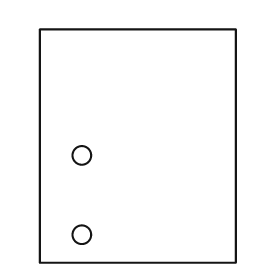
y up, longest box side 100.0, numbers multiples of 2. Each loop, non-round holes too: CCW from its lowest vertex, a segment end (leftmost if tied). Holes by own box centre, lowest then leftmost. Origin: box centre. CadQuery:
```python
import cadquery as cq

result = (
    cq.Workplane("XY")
    .moveTo(-42.0, -50.0)
    .lineTo(42.0, -50.0)
    .lineTo(42.0, 50.0)
    .lineTo(-42.0, 50.0)
    .close()
    .moveTo(-24.0, -38.0)
    .circle(4.0)
    .moveTo(-24.0, -4.0)
    .circle(4.0)
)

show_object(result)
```